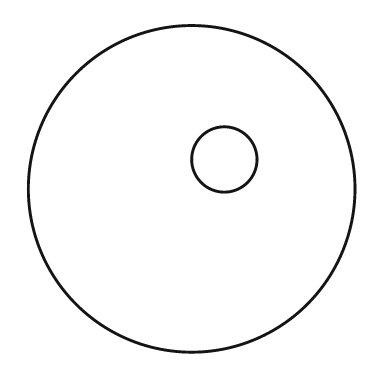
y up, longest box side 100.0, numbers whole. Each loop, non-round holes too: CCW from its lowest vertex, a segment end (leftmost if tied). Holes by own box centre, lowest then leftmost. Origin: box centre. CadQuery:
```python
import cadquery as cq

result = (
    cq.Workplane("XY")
    .moveTo(0.0, 0.0)
    .circle(50.0)
    .moveTo(10.0, 9.0)
    .circle(10.0)
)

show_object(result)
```